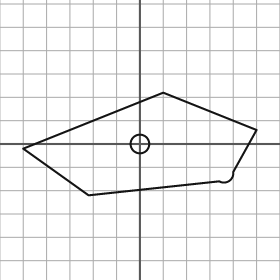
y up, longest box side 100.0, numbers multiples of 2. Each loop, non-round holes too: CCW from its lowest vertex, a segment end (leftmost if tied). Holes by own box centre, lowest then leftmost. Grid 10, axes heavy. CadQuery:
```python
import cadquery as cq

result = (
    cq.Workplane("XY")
    .moveTo(-22.0, -22.0)
    .lineTo(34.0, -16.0)
    .threePointArc((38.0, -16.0), (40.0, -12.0))
    .lineTo(50.0, 6.0)
    .lineTo(10.0, 22.0)
    .lineTo(-50.0, -2.0)
    .close()
    .moveTo(0.0, 0.0)
    .circle(4.0)
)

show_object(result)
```